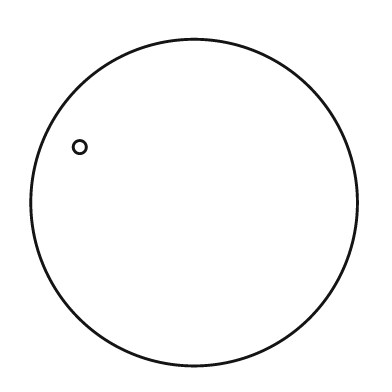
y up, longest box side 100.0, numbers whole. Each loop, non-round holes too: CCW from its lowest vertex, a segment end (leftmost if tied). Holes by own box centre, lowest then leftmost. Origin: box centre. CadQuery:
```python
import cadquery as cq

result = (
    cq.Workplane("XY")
    .moveTo(0.0, 0.0)
    .circle(50.0)
    .moveTo(-35.0, 17.0)
    .circle(2.0)
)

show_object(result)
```